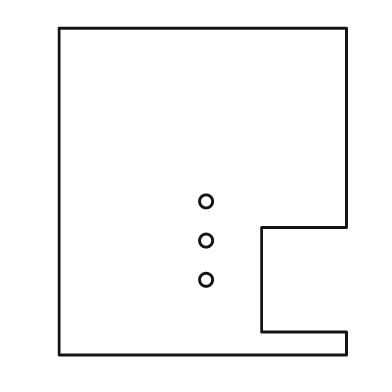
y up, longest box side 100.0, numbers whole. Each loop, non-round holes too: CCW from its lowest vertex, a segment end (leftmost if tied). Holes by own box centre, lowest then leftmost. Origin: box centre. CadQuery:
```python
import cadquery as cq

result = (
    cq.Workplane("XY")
    .moveTo(-44.0, -50.0)
    .lineTo(44.0, -50.0)
    .lineTo(44.0, -43.0)
    .lineTo(18.0, -43.0)
    .lineTo(18.0, -11.0)
    .lineTo(44.0, -11.0)
    .lineTo(44.0, 50.0)
    .lineTo(-44.0, 50.0)
    .close()
    .moveTo(1.0, -27.0)
    .circle(2.0)
    .moveTo(1.0, -15.0)
    .circle(2.0)
    .moveTo(1.0, -3.0)
    .circle(2.0)
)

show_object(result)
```